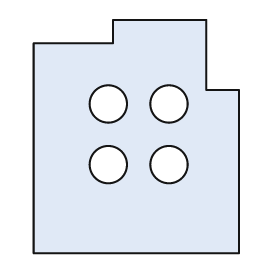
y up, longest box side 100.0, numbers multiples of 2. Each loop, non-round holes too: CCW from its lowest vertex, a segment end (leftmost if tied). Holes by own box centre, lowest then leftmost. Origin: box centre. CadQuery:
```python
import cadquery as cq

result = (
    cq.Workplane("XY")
    .moveTo(-44.0, -50.0)
    .lineTo(44.0, -50.0)
    .lineTo(44.0, 20.0)
    .lineTo(30.0, 20.0)
    .lineTo(30.0, 50.0)
    .lineTo(-10.0, 50.0)
    .lineTo(-10.0, 40.0)
    .lineTo(-44.0, 40.0)
    .close()
    .moveTo(-12.0, -12.0)
    .circle(8.0)
    .moveTo(14.0, -12.0)
    .circle(8.0)
    .moveTo(-12.0, 14.0)
    .circle(8.0)
    .moveTo(14.0, 14.0)
    .circle(8.0)
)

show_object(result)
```